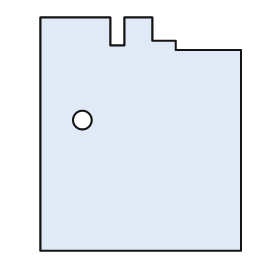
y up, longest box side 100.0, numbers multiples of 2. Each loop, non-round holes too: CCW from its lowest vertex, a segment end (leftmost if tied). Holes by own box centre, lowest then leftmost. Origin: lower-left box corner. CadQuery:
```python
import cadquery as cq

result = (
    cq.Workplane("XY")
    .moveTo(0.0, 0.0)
    .lineTo(86.0, 0.0)
    .lineTo(86.0, 86.0)
    .lineTo(58.0, 86.0)
    .lineTo(58.0, 90.0)
    .lineTo(48.0, 90.0)
    .lineTo(48.0, 100.0)
    .lineTo(36.0, 100.0)
    .lineTo(36.0, 88.0)
    .lineTo(30.0, 88.0)
    .lineTo(30.0, 100.0)
    .lineTo(0.0, 100.0)
    .close()
    .moveTo(18.0, 56.0)
    .circle(4.0)
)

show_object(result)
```